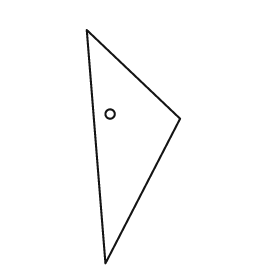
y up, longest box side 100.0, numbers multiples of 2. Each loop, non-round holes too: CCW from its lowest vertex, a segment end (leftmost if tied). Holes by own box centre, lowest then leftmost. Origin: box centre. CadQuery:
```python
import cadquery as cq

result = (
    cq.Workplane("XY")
    .moveTo(-12.0, -50.0)
    .lineTo(20.0, 12.0)
    .lineTo(-20.0, 50.0)
    .close()
    .moveTo(-10.0, 14.0)
    .circle(2.0)
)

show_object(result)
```